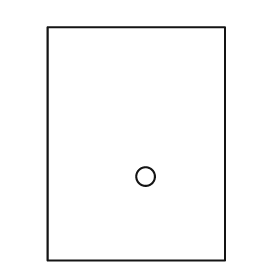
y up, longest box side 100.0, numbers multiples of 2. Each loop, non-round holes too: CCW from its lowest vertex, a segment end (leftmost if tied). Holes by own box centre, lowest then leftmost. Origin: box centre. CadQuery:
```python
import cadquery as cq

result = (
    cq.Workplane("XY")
    .moveTo(-38.0, -50.0)
    .lineTo(38.0, -50.0)
    .lineTo(38.0, 50.0)
    .lineTo(-38.0, 50.0)
    .close()
    .moveTo(4.0, -14.0)
    .circle(4.0)
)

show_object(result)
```